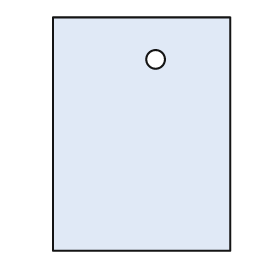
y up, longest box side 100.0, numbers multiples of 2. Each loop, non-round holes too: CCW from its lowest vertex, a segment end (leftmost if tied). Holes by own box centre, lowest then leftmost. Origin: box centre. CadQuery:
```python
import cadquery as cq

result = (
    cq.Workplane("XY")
    .moveTo(-38.0, -50.0)
    .lineTo(38.0, -50.0)
    .lineTo(38.0, 50.0)
    .lineTo(-38.0, 50.0)
    .close()
    .moveTo(6.0, 32.0)
    .circle(4.0)
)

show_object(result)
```